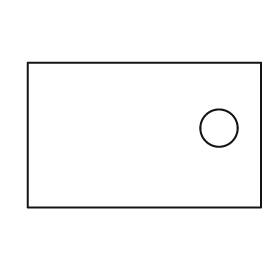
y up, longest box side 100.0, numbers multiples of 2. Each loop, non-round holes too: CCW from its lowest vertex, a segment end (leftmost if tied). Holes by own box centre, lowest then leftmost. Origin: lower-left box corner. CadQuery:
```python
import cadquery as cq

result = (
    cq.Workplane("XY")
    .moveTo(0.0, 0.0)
    .lineTo(100.0, 0.0)
    .lineTo(100.0, 62.0)
    .lineTo(0.0, 62.0)
    .close()
    .moveTo(82.0, 34.0)
    .circle(8.0)
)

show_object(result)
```